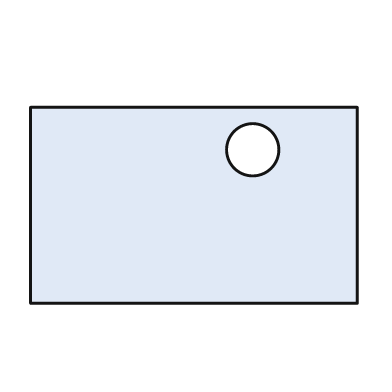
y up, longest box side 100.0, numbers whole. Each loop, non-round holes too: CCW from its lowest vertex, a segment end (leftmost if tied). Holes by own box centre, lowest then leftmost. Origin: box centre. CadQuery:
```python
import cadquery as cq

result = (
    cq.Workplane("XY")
    .moveTo(-50.0, -30.0)
    .lineTo(50.0, -30.0)
    .lineTo(50.0, 30.0)
    .lineTo(-50.0, 30.0)
    .close()
    .moveTo(18.0, 17.0)
    .circle(8.0)
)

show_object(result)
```